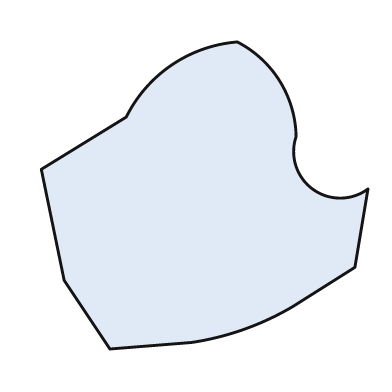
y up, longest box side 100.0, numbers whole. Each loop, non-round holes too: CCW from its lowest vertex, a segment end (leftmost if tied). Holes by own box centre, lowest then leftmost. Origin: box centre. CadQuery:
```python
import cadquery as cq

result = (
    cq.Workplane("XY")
    .moveTo(-29.0, -47.0)
    .lineTo(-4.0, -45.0)
    .threePointArc((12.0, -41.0), (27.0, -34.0))
    .lineTo(46.0, -22.0)
    .lineTo(50.0, 2.0)
    .threePointArc((33.0, 2.0), (28.0, 18.0))
    .threePointArc((23.0, 35.0), (10.0, 47.0))
    .threePointArc((-10.0, 40.0), (-24.0, 24.0))
    .lineTo(-50.0, 8.0)
    .lineTo(-43.0, -26.0)
    .close()
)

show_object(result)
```